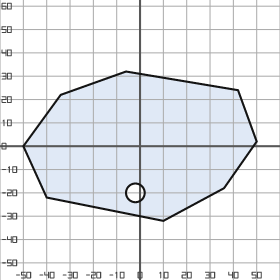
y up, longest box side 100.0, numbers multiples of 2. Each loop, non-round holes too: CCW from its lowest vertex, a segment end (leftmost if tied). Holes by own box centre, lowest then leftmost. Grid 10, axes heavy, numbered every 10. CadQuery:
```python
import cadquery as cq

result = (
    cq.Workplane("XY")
    .moveTo(10.0, -32.0)
    .lineTo(36.0, -18.0)
    .lineTo(50.0, 2.0)
    .lineTo(42.0, 24.0)
    .lineTo(-6.0, 32.0)
    .lineTo(-34.0, 22.0)
    .lineTo(-50.0, 0.0)
    .lineTo(-40.0, -22.0)
    .close()
    .moveTo(-2.0, -20.0)
    .circle(4.0)
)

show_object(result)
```